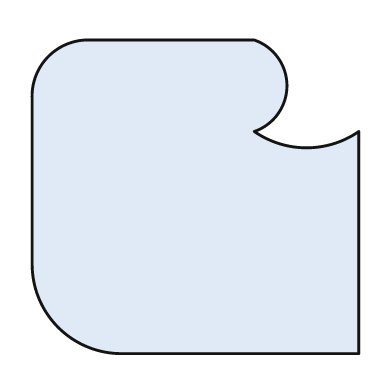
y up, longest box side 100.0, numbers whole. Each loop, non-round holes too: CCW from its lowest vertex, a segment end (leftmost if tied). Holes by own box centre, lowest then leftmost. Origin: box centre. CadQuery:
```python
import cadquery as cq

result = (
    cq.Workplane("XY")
    .moveTo(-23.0, -48.0)
    .lineTo(50.0, -48.0)
    .lineTo(50.0, 20.0)
    .threePointArc((34.0, 15.0), (18.0, 20.0))
    .threePointArc((28.0, 34.0), (18.0, 48.0))
    .lineTo(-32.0, 48.0)
    .threePointArc((-45.0, 43.0), (-50.0, 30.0))
    .lineTo(-50.0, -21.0)
    .threePointArc((-42.0, -40.0), (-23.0, -48.0))
    .close()
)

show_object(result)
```